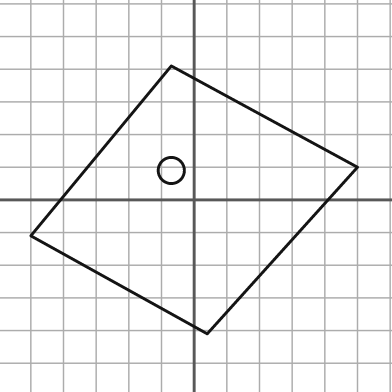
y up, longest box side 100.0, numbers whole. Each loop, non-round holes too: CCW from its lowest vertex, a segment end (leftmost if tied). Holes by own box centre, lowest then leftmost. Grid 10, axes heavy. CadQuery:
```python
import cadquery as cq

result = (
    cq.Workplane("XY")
    .moveTo(4.0, -41.0)
    .lineTo(50.0, 10.0)
    .lineTo(-7.0, 41.0)
    .lineTo(-50.0, -11.0)
    .close()
    .moveTo(-7.0, 9.0)
    .circle(4.0)
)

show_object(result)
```